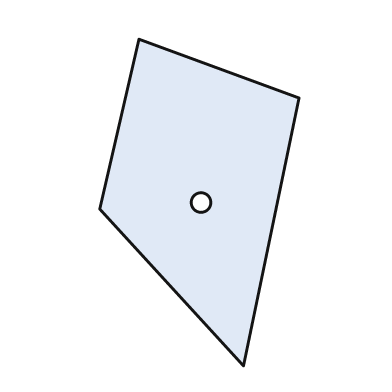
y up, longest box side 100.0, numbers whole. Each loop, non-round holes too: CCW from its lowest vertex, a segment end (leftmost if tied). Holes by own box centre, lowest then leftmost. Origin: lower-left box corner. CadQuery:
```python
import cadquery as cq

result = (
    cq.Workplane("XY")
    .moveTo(44.0, 0.0)
    .lineTo(61.0, 82.0)
    .lineTo(12.0, 100.0)
    .lineTo(0.0, 48.0)
    .close()
    .moveTo(31.0, 50.0)
    .circle(3.0)
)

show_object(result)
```